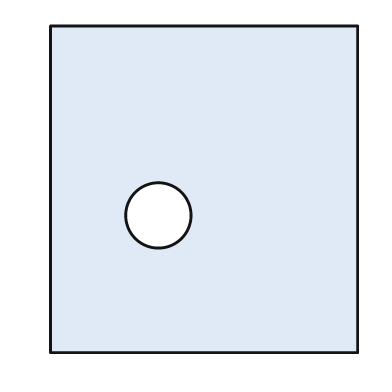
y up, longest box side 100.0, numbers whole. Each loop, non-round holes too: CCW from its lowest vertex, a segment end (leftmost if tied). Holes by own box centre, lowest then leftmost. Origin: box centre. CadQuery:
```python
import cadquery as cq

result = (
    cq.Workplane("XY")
    .moveTo(-47.0, -50.0)
    .lineTo(47.0, -50.0)
    .lineTo(47.0, 50.0)
    .lineTo(-47.0, 50.0)
    .close()
    .moveTo(-14.0, -8.0)
    .circle(10.0)
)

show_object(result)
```